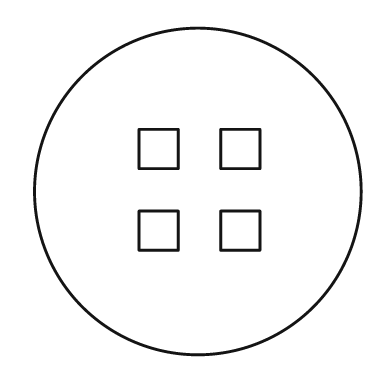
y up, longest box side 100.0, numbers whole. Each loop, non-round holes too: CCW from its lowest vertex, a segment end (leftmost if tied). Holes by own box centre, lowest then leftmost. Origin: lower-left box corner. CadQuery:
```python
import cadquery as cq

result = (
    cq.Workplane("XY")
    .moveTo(50.0, 50.0)
    .circle(50.0)
    .moveTo(32.0, 32.0)
    .lineTo(44.0, 32.0)
    .lineTo(44.0, 44.0)
    .lineTo(32.0, 44.0)
    .close()
    .moveTo(57.0, 32.0)
    .lineTo(69.0, 32.0)
    .lineTo(69.0, 44.0)
    .lineTo(57.0, 44.0)
    .close()
    .moveTo(32.0, 57.0)
    .lineTo(44.0, 57.0)
    .lineTo(44.0, 69.0)
    .lineTo(32.0, 69.0)
    .close()
    .moveTo(57.0, 57.0)
    .lineTo(69.0, 57.0)
    .lineTo(69.0, 69.0)
    .lineTo(57.0, 69.0)
    .close()
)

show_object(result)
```